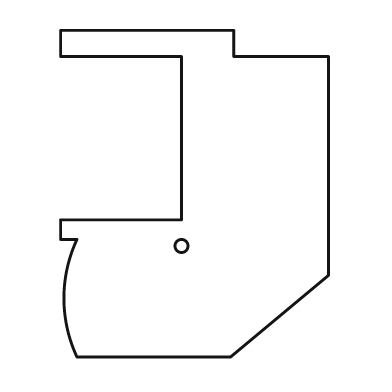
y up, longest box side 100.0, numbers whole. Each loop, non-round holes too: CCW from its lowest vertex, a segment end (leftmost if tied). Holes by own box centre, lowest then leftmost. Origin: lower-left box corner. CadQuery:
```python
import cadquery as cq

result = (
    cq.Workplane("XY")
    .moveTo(5.0, 0.0)
    .lineTo(52.0, 0.0)
    .lineTo(82.0, 25.0)
    .lineTo(82.0, 92.0)
    .lineTo(53.0, 92.0)
    .lineTo(53.0, 100.0)
    .lineTo(0.0, 100.0)
    .lineTo(0.0, 92.0)
    .lineTo(37.0, 92.0)
    .lineTo(37.0, 42.0)
    .lineTo(0.0, 42.0)
    .lineTo(0.0, 36.0)
    .lineTo(5.0, 36.0)
    .threePointArc((1.0, 18.0), (5.0, 0.0))
    .close()
    .moveTo(37.0, 34.0)
    .circle(2.0)
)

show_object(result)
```